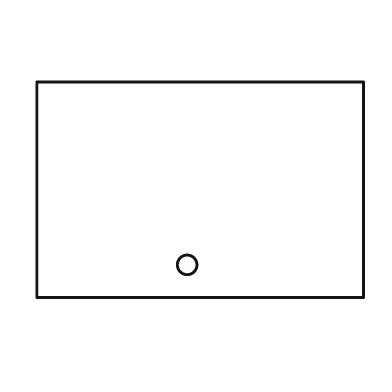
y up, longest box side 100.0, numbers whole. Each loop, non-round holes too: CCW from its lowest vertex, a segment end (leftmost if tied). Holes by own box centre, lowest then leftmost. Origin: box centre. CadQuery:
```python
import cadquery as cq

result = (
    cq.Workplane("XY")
    .moveTo(-50.0, -33.0)
    .lineTo(50.0, -33.0)
    .lineTo(50.0, 33.0)
    .lineTo(-50.0, 33.0)
    .close()
    .moveTo(-4.0, -23.0)
    .circle(3.0)
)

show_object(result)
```